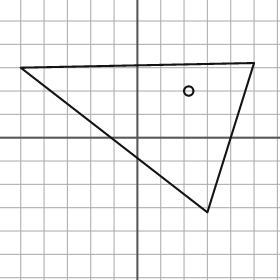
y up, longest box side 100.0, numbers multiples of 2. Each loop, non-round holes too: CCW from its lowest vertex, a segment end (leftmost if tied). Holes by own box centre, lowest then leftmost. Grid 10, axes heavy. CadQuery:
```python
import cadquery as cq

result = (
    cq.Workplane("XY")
    .moveTo(30.0, -32.0)
    .lineTo(50.0, 32.0)
    .lineTo(-50.0, 30.0)
    .close()
    .moveTo(22.0, 20.0)
    .circle(2.0)
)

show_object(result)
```